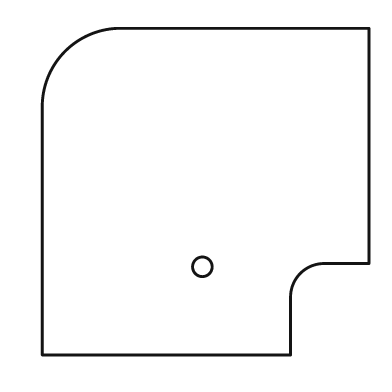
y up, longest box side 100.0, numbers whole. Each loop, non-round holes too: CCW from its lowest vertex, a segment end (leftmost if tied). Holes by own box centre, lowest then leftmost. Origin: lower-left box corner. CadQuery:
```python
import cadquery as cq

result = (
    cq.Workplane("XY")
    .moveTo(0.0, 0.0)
    .lineTo(76.0, 0.0)
    .lineTo(76.0, 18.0)
    .threePointArc((79.0, 25.0), (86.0, 28.0))
    .lineTo(100.0, 28.0)
    .lineTo(100.0, 100.0)
    .lineTo(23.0, 100.0)
    .threePointArc((7.0, 93.0), (0.0, 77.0))
    .close()
    .moveTo(49.0, 27.0)
    .circle(3.0)
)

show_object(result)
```